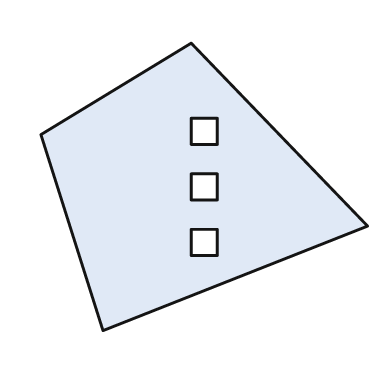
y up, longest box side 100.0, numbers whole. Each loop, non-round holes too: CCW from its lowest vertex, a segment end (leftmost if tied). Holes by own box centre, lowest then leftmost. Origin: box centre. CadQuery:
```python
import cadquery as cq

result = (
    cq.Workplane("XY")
    .moveTo(-31.0, -44.0)
    .lineTo(50.0, -12.0)
    .lineTo(-4.0, 44.0)
    .lineTo(-50.0, 16.0)
    .close()
    .moveTo(-4.0, -21.0)
    .lineTo(4.0, -21.0)
    .lineTo(4.0, -13.0)
    .lineTo(-4.0, -13.0)
    .close()
    .moveTo(-4.0, -4.0)
    .lineTo(4.0, -4.0)
    .lineTo(4.0, 4.0)
    .lineTo(-4.0, 4.0)
    .close()
    .moveTo(-4.0, 13.0)
    .lineTo(4.0, 13.0)
    .lineTo(4.0, 21.0)
    .lineTo(-4.0, 21.0)
    .close()
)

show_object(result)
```